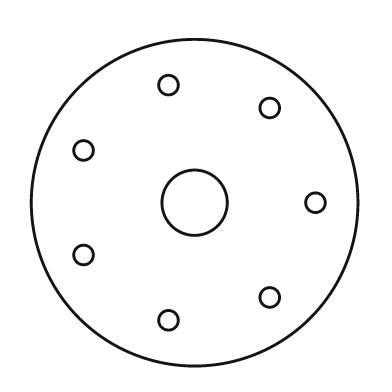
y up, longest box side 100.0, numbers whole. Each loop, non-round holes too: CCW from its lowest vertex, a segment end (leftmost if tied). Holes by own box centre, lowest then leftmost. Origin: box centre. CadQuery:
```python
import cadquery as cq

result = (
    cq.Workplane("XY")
    .moveTo(0.0, 0.0)
    .circle(50.0)
    .moveTo(-8.0, -36.0)
    .circle(3.0)
    .moveTo(23.0, -29.0)
    .circle(3.0)
    .moveTo(-34.0, -16.0)
    .circle(3.0)
    .moveTo(0.0, 0.0)
    .circle(10.0)
    .moveTo(37.0, 0.0)
    .circle(3.0)
    .moveTo(-34.0, 16.0)
    .circle(3.0)
    .moveTo(23.0, 29.0)
    .circle(3.0)
    .moveTo(-8.0, 36.0)
    .circle(3.0)
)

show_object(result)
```